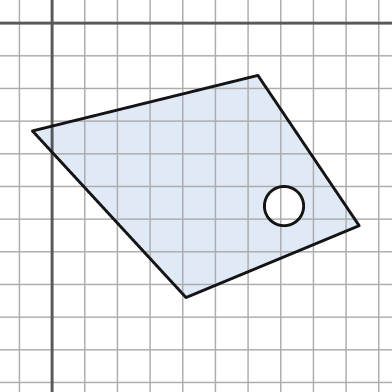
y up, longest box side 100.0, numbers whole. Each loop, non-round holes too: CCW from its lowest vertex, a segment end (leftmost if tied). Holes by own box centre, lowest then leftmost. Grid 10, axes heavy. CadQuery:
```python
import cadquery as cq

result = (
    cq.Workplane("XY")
    .moveTo(41.0, -84.0)
    .lineTo(94.0, -62.0)
    .lineTo(63.0, -16.0)
    .lineTo(-6.0, -33.0)
    .close()
    .moveTo(71.0, -56.0)
    .circle(6.0)
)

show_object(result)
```